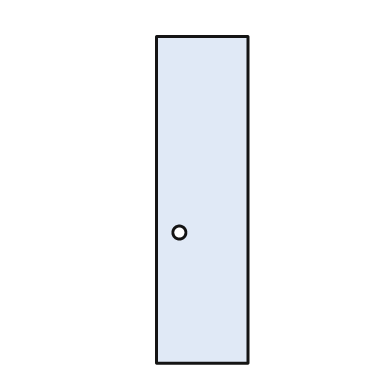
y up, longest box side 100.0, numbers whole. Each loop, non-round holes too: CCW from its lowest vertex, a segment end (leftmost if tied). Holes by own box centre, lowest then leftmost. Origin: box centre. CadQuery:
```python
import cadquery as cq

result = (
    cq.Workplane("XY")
    .moveTo(-14.0, -50.0)
    .lineTo(14.0, -50.0)
    .lineTo(14.0, 50.0)
    .lineTo(-14.0, 50.0)
    .close()
    .moveTo(-7.0, -10.0)
    .circle(2.0)
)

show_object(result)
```